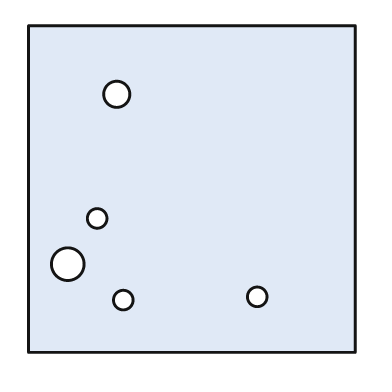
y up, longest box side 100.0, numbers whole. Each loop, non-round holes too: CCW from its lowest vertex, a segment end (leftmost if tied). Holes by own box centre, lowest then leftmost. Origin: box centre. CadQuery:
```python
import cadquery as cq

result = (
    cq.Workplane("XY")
    .moveTo(-50.0, -50.0)
    .lineTo(50.0, -50.0)
    .lineTo(50.0, 50.0)
    .lineTo(-50.0, 50.0)
    .close()
    .moveTo(-21.0, -34.0)
    .circle(3.0)
    .moveTo(20.0, -33.0)
    .circle(3.0)
    .moveTo(-38.0, -23.0)
    .circle(5.0)
    .moveTo(-29.0, -9.0)
    .circle(3.0)
    .moveTo(-23.0, 29.0)
    .circle(4.0)
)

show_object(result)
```